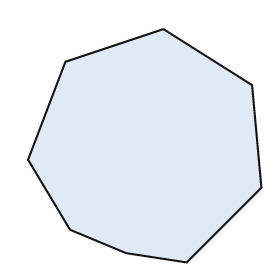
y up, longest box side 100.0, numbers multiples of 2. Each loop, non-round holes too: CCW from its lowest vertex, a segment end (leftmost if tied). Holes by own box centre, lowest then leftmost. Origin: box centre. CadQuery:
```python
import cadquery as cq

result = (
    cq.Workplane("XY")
    .moveTo(18.0, -50.0)
    .lineTo(50.0, -18.0)
    .lineTo(46.0, 26.0)
    .lineTo(8.0, 50.0)
    .lineTo(-34.0, 36.0)
    .lineTo(-50.0, -6.0)
    .lineTo(-32.0, -36.0)
    .lineTo(-8.0, -46.0)
    .close()
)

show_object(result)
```